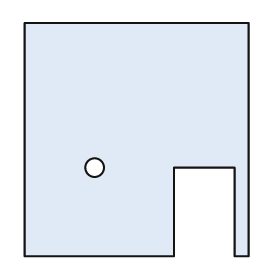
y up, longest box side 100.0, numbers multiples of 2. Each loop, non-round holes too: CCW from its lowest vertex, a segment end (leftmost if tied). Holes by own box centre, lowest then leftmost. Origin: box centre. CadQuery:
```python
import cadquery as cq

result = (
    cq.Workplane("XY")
    .moveTo(-48.0, -50.0)
    .lineTo(16.0, -50.0)
    .lineTo(16.0, -12.0)
    .lineTo(42.0, -12.0)
    .lineTo(42.0, -50.0)
    .lineTo(48.0, -50.0)
    .lineTo(48.0, 50.0)
    .lineTo(-48.0, 50.0)
    .close()
    .moveTo(-18.0, -12.0)
    .circle(4.0)
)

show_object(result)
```